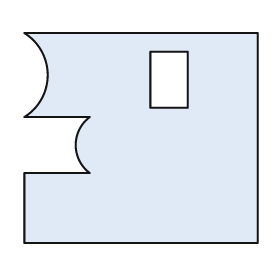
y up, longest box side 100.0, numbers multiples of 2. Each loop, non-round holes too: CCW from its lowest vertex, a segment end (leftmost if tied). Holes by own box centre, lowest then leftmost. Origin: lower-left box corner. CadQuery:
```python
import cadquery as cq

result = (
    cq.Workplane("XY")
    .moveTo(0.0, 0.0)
    .lineTo(100.0, 0.0)
    .lineTo(100.0, 90.0)
    .lineTo(0.0, 90.0)
    .threePointArc((10.0, 72.0), (0.0, 54.0))
    .lineTo(28.0, 54.0)
    .threePointArc((22.0, 42.0), (28.0, 30.0))
    .lineTo(0.0, 30.0)
    .close()
    .moveTo(54.0, 58.0)
    .lineTo(70.0, 58.0)
    .lineTo(70.0, 82.0)
    .lineTo(54.0, 82.0)
    .close()
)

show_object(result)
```